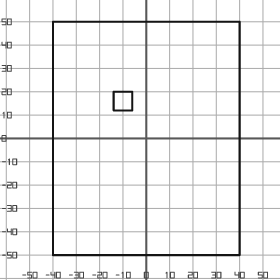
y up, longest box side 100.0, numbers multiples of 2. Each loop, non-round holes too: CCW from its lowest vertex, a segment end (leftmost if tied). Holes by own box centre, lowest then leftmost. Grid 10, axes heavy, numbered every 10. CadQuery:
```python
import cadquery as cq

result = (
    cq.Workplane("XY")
    .moveTo(-40.0, -50.0)
    .lineTo(40.0, -50.0)
    .lineTo(40.0, 50.0)
    .lineTo(-40.0, 50.0)
    .close()
    .moveTo(-14.0, 12.0)
    .lineTo(-6.0, 12.0)
    .lineTo(-6.0, 20.0)
    .lineTo(-14.0, 20.0)
    .close()
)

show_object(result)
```